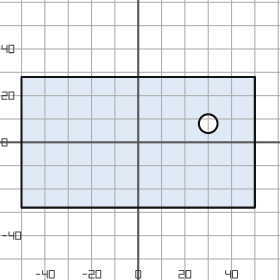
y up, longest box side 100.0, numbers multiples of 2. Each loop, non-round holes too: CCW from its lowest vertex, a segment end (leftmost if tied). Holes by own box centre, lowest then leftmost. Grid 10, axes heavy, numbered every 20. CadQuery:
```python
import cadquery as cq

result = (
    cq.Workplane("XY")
    .moveTo(-50.0, -28.0)
    .lineTo(50.0, -28.0)
    .lineTo(50.0, 28.0)
    .lineTo(-50.0, 28.0)
    .close()
    .moveTo(30.0, 8.0)
    .circle(4.0)
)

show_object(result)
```